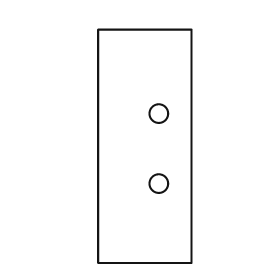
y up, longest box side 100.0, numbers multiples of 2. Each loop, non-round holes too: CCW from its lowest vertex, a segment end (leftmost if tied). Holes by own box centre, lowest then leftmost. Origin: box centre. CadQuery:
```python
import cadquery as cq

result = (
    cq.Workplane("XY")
    .moveTo(-20.0, -50.0)
    .lineTo(20.0, -50.0)
    .lineTo(20.0, 50.0)
    .lineTo(-20.0, 50.0)
    .close()
    .moveTo(6.0, -16.0)
    .circle(4.0)
    .moveTo(6.0, 14.0)
    .circle(4.0)
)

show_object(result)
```